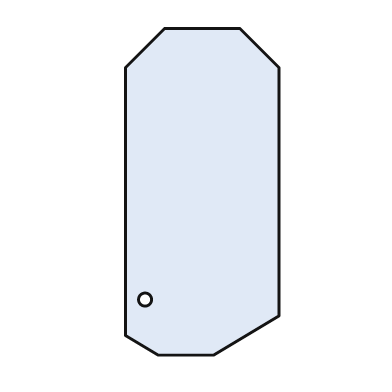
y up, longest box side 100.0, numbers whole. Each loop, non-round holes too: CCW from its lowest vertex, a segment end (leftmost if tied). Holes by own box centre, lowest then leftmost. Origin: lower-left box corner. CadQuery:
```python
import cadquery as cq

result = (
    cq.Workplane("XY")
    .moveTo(10.0, 0.0)
    .lineTo(27.0, 0.0)
    .lineTo(47.0, 12.0)
    .lineTo(47.0, 88.0)
    .lineTo(35.0, 100.0)
    .lineTo(12.0, 100.0)
    .lineTo(0.0, 88.0)
    .lineTo(0.0, 6.0)
    .close()
    .moveTo(6.0, 17.0)
    .circle(2.0)
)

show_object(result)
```